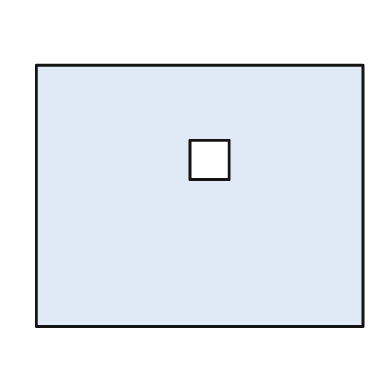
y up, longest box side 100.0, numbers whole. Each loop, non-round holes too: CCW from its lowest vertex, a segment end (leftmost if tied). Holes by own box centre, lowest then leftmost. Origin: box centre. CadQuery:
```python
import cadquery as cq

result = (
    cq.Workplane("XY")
    .moveTo(-50.0, -40.0)
    .lineTo(50.0, -40.0)
    .lineTo(50.0, 40.0)
    .lineTo(-50.0, 40.0)
    .close()
    .moveTo(-3.0, 5.0)
    .lineTo(9.0, 5.0)
    .lineTo(9.0, 17.0)
    .lineTo(-3.0, 17.0)
    .close()
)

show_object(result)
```